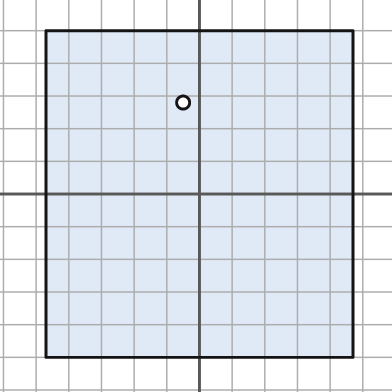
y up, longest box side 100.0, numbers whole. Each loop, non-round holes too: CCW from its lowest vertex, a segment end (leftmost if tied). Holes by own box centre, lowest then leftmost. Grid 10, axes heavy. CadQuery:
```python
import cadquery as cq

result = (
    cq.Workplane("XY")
    .moveTo(-47.0, -50.0)
    .lineTo(47.0, -50.0)
    .lineTo(47.0, 50.0)
    .lineTo(-47.0, 50.0)
    .close()
    .moveTo(-5.0, 28.0)
    .circle(2.0)
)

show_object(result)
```